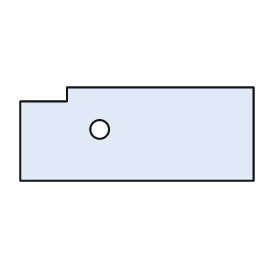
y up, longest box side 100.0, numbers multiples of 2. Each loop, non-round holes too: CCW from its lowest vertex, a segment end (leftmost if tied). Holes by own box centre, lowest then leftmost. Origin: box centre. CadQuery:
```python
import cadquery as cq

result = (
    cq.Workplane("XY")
    .moveTo(-50.0, -20.0)
    .lineTo(50.0, -20.0)
    .lineTo(50.0, 20.0)
    .lineTo(-30.0, 20.0)
    .lineTo(-30.0, 14.0)
    .lineTo(-50.0, 14.0)
    .close()
    .moveTo(-16.0, 2.0)
    .circle(4.0)
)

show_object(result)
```